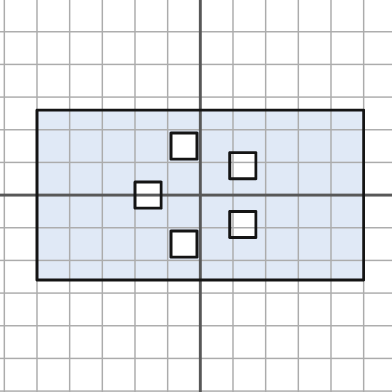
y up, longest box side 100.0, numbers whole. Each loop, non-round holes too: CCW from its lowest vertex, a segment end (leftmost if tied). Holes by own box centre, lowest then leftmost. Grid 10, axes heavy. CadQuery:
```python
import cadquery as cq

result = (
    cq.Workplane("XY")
    .moveTo(-50.0, -26.0)
    .lineTo(50.0, -26.0)
    .lineTo(50.0, 26.0)
    .lineTo(-50.0, 26.0)
    .close()
    .moveTo(-9.0, -19.0)
    .lineTo(-1.0, -19.0)
    .lineTo(-1.0, -11.0)
    .lineTo(-9.0, -11.0)
    .close()
    .moveTo(9.0, -13.0)
    .lineTo(17.0, -13.0)
    .lineTo(17.0, -5.0)
    .lineTo(9.0, -5.0)
    .close()
    .moveTo(-20.0, -4.0)
    .lineTo(-12.0, -4.0)
    .lineTo(-12.0, 4.0)
    .lineTo(-20.0, 4.0)
    .close()
    .moveTo(9.0, 5.0)
    .lineTo(17.0, 5.0)
    .lineTo(17.0, 13.0)
    .lineTo(9.0, 13.0)
    .close()
    .moveTo(-9.0, 11.0)
    .lineTo(-1.0, 11.0)
    .lineTo(-1.0, 19.0)
    .lineTo(-9.0, 19.0)
    .close()
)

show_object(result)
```